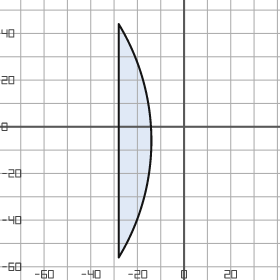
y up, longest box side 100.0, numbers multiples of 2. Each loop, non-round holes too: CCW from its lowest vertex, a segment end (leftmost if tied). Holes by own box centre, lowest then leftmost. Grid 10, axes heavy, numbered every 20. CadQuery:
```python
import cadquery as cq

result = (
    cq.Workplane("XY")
    .moveTo(-28.0, -56.0)
    .threePointArc((-14.0, -6.0), (-28.0, 44.0))
    .close()
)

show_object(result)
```